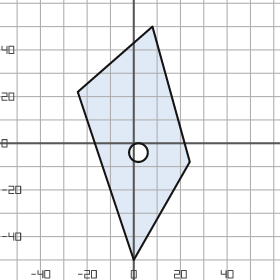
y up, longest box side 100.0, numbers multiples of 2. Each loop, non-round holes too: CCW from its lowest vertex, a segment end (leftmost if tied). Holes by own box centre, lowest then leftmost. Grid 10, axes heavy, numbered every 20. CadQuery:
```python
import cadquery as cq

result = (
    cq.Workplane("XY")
    .moveTo(0.0, -50.0)
    .lineTo(24.0, -8.0)
    .lineTo(8.0, 50.0)
    .lineTo(-24.0, 22.0)
    .close()
    .moveTo(2.0, -4.0)
    .circle(4.0)
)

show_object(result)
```